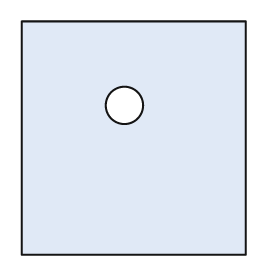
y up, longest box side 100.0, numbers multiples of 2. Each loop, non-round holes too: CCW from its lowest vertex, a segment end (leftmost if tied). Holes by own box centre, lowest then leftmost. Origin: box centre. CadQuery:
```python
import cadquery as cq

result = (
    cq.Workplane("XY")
    .moveTo(-48.0, -50.0)
    .lineTo(48.0, -50.0)
    .lineTo(48.0, 50.0)
    .lineTo(-48.0, 50.0)
    .close()
    .moveTo(-4.0, 14.0)
    .circle(8.0)
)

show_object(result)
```